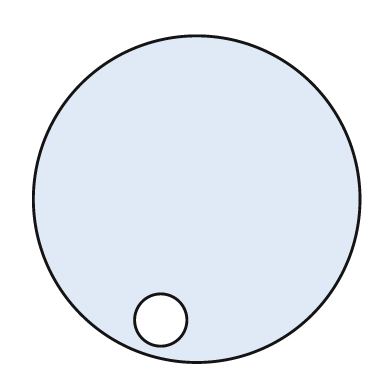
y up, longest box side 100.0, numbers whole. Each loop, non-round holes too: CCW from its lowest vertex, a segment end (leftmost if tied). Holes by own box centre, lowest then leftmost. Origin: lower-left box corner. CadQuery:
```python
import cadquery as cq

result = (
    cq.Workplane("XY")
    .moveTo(50.0, 50.0)
    .circle(50.0)
    .moveTo(39.0, 13.0)
    .circle(8.0)
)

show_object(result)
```